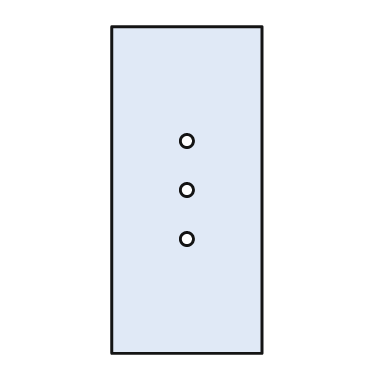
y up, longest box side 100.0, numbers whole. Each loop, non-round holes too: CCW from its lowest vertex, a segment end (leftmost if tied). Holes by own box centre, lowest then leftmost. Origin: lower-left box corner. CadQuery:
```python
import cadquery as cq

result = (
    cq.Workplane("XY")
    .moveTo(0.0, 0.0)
    .lineTo(46.0, 0.0)
    .lineTo(46.0, 100.0)
    .lineTo(0.0, 100.0)
    .close()
    .moveTo(23.0, 35.0)
    .circle(2.0)
    .moveTo(23.0, 50.0)
    .circle(2.0)
    .moveTo(23.0, 65.0)
    .circle(2.0)
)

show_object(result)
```